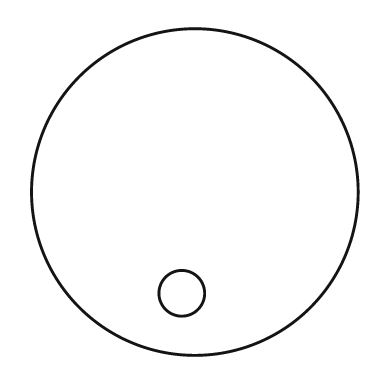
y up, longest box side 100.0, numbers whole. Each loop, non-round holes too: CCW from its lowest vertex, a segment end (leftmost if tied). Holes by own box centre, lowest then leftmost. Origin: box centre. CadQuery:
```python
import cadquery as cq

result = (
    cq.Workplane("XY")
    .moveTo(0.0, 0.0)
    .circle(50.0)
    .moveTo(-4.0, -31.0)
    .circle(7.0)
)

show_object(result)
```